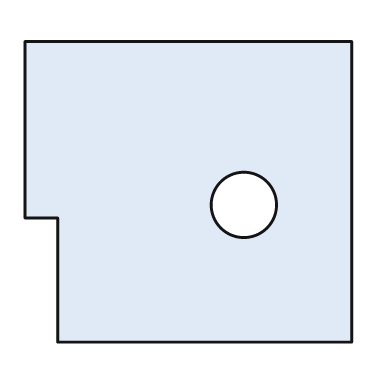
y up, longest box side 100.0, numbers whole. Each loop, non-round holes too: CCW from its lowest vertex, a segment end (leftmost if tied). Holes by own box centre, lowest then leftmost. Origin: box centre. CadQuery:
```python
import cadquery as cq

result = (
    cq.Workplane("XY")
    .moveTo(-40.0, -46.0)
    .lineTo(50.0, -46.0)
    .lineTo(50.0, 46.0)
    .lineTo(-50.0, 46.0)
    .lineTo(-50.0, -8.0)
    .lineTo(-40.0, -8.0)
    .close()
    .moveTo(17.0, -4.0)
    .circle(10.0)
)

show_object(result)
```